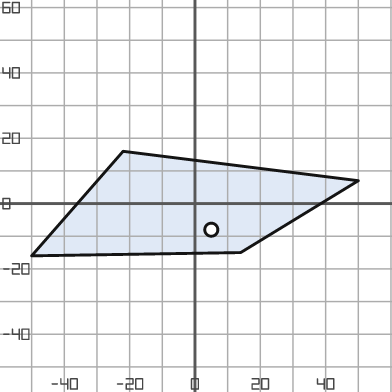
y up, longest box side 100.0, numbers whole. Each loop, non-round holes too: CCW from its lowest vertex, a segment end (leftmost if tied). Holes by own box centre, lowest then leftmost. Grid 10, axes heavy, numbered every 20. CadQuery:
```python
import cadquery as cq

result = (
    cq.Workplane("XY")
    .moveTo(-50.0, -16.0)
    .lineTo(14.0, -15.0)
    .lineTo(50.0, 7.0)
    .lineTo(-22.0, 16.0)
    .close()
    .moveTo(5.0, -8.0)
    .circle(2.0)
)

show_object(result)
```